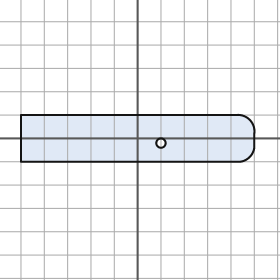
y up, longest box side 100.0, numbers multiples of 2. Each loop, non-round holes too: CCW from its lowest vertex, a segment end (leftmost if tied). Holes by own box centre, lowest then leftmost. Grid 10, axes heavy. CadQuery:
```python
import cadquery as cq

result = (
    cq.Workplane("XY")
    .moveTo(-50.0, -10.0)
    .lineTo(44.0, -10.0)
    .threePointArc((48.0, -8.0), (50.0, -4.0))
    .lineTo(50.0, 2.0)
    .threePointArc((48.0, 8.0), (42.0, 10.0))
    .lineTo(-50.0, 10.0)
    .close()
    .moveTo(10.0, -2.0)
    .circle(2.0)
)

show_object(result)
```